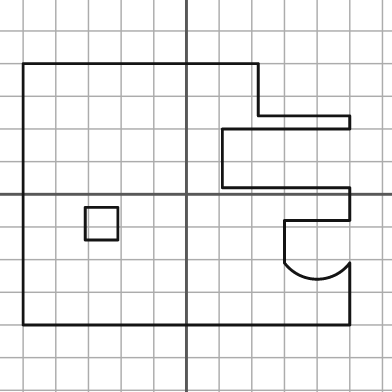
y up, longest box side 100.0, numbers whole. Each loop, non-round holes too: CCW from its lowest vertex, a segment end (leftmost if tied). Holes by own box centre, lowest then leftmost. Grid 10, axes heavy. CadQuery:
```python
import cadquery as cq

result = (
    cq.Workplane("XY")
    .moveTo(-50.0, -40.0)
    .lineTo(50.0, -40.0)
    .lineTo(50.0, -21.0)
    .threePointArc((40.0, -26.0), (30.0, -21.0))
    .lineTo(30.0, -8.0)
    .lineTo(50.0, -8.0)
    .lineTo(50.0, 2.0)
    .lineTo(11.0, 2.0)
    .lineTo(11.0, 20.0)
    .lineTo(50.0, 20.0)
    .lineTo(50.0, 24.0)
    .lineTo(22.0, 24.0)
    .lineTo(22.0, 40.0)
    .lineTo(-50.0, 40.0)
    .close()
    .moveTo(-31.0, -14.0)
    .lineTo(-21.0, -14.0)
    .lineTo(-21.0, -4.0)
    .lineTo(-31.0, -4.0)
    .close()
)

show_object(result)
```